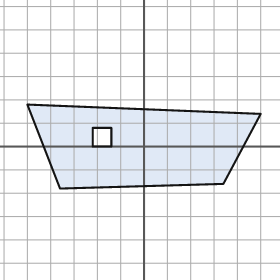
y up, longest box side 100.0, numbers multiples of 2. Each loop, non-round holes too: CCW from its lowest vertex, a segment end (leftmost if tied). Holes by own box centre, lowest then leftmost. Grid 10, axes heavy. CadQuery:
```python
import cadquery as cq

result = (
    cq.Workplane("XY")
    .moveTo(-36.0, -18.0)
    .lineTo(34.0, -16.0)
    .lineTo(50.0, 14.0)
    .lineTo(-50.0, 18.0)
    .close()
    .moveTo(-22.0, 0.0)
    .lineTo(-14.0, 0.0)
    .lineTo(-14.0, 8.0)
    .lineTo(-22.0, 8.0)
    .close()
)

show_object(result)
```